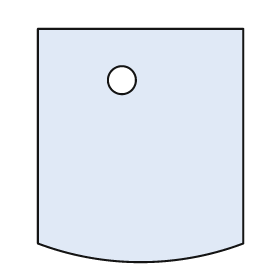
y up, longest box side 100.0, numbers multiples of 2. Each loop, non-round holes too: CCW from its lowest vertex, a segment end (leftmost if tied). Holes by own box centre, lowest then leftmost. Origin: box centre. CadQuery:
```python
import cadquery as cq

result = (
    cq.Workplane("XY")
    .moveTo(-44.0, -42.0)
    .threePointArc((0.0, -50.0), (44.0, -42.0))
    .lineTo(44.0, 50.0)
    .lineTo(-44.0, 50.0)
    .close()
    .moveTo(-8.0, 28.0)
    .circle(6.0)
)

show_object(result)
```